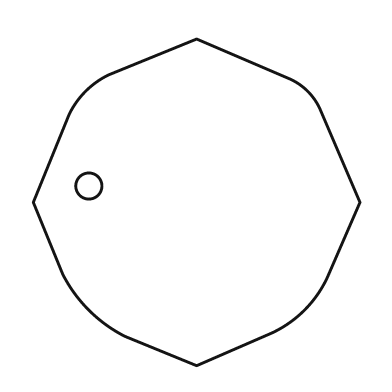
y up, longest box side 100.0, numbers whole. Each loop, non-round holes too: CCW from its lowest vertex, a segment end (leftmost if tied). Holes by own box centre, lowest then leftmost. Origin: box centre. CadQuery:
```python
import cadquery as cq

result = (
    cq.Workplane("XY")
    .moveTo(0.0, -50.0)
    .lineTo(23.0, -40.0)
    .threePointArc((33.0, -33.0), (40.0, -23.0))
    .lineTo(50.0, 0.0)
    .lineTo(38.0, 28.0)
    .threePointArc((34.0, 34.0), (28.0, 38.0))
    .lineTo(0.0, 50.0)
    .lineTo(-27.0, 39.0)
    .threePointArc((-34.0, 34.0), (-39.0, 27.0))
    .lineTo(-50.0, 0.0)
    .lineTo(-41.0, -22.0)
    .threePointArc((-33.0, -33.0), (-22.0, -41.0))
    .close()
    .moveTo(-33.0, 5.0)
    .circle(4.0)
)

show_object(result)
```